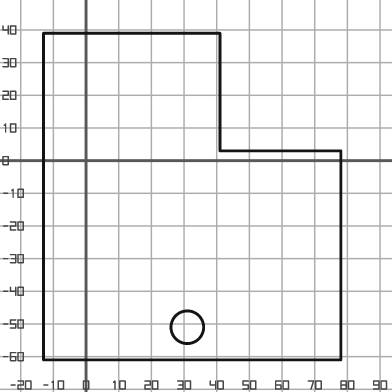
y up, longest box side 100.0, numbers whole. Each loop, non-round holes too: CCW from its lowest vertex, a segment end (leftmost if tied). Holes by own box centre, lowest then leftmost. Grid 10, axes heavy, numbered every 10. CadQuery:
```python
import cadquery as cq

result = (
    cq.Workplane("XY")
    .moveTo(-13.0, -61.0)
    .lineTo(78.0, -61.0)
    .lineTo(78.0, 3.0)
    .lineTo(41.0, 3.0)
    .lineTo(41.0, 39.0)
    .lineTo(-13.0, 39.0)
    .close()
    .moveTo(31.0, -51.0)
    .circle(5.0)
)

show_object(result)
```